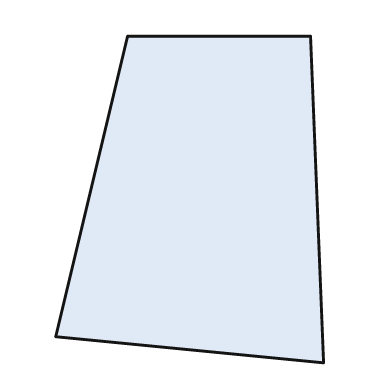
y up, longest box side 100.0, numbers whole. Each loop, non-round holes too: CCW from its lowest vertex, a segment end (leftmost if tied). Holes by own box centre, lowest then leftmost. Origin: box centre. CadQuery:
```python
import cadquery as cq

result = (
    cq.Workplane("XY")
    .moveTo(41.0, -50.0)
    .lineTo(37.0, 50.0)
    .lineTo(-19.0, 50.0)
    .lineTo(-41.0, -42.0)
    .close()
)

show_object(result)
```